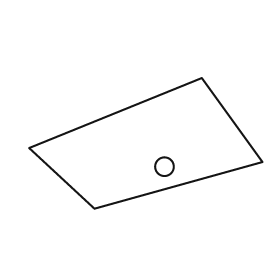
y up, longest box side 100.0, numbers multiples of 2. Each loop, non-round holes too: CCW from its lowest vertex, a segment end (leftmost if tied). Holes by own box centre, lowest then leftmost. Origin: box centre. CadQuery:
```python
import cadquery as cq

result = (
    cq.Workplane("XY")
    .moveTo(-22.0, -28.0)
    .lineTo(50.0, -8.0)
    .lineTo(24.0, 28.0)
    .lineTo(-50.0, -2.0)
    .close()
    .moveTo(8.0, -10.0)
    .circle(4.0)
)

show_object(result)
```